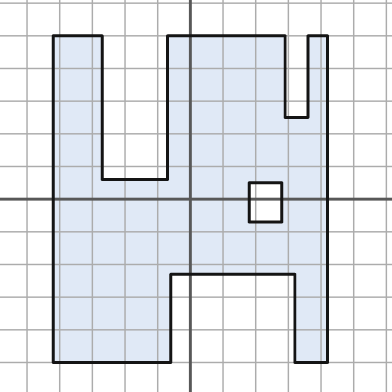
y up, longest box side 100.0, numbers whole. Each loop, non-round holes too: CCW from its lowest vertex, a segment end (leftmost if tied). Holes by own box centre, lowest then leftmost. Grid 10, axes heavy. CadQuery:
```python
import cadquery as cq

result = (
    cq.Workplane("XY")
    .moveTo(-42.0, -50.0)
    .lineTo(-6.0, -50.0)
    .lineTo(-6.0, -23.0)
    .lineTo(32.0, -23.0)
    .lineTo(32.0, -50.0)
    .lineTo(42.0, -50.0)
    .lineTo(42.0, 50.0)
    .lineTo(36.0, 50.0)
    .lineTo(36.0, 25.0)
    .lineTo(29.0, 25.0)
    .lineTo(29.0, 50.0)
    .lineTo(-7.0, 50.0)
    .lineTo(-7.0, 6.0)
    .lineTo(-27.0, 6.0)
    .lineTo(-27.0, 50.0)
    .lineTo(-42.0, 50.0)
    .close()
    .moveTo(18.0, -7.0)
    .lineTo(28.0, -7.0)
    .lineTo(28.0, 5.0)
    .lineTo(18.0, 5.0)
    .close()
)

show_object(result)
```